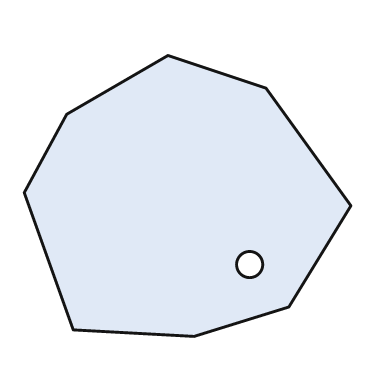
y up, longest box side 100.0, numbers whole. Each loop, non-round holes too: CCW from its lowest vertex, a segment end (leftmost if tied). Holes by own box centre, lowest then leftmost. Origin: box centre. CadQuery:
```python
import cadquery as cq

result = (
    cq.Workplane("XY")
    .moveTo(2.0, -43.0)
    .lineTo(31.0, -34.0)
    .lineTo(50.0, -3.0)
    .lineTo(24.0, 33.0)
    .lineTo(-6.0, 43.0)
    .lineTo(-37.0, 25.0)
    .lineTo(-50.0, 1.0)
    .lineTo(-35.0, -41.0)
    .close()
    .moveTo(19.0, -21.0)
    .circle(4.0)
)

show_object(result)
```